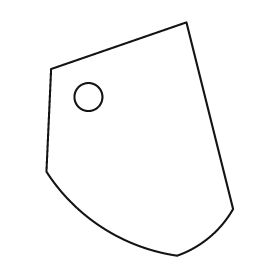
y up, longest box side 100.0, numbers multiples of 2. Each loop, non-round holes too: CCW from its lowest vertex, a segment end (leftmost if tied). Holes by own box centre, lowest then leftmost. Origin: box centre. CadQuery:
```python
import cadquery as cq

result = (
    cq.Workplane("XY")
    .moveTo(16.0, -50.0)
    .threePointArc((30.0, -42.0), (40.0, -30.0))
    .lineTo(20.0, 50.0)
    .lineTo(-38.0, 30.0)
    .lineTo(-40.0, -14.0)
    .threePointArc((-16.0, -38.0), (16.0, -50.0))
    .close()
    .moveTo(-22.0, 18.0)
    .circle(6.0)
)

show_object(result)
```